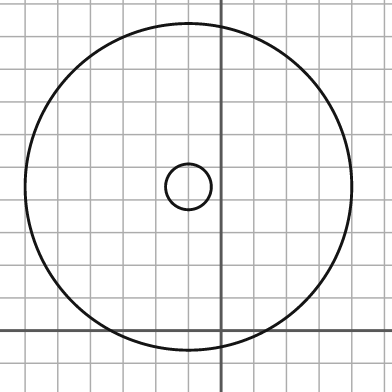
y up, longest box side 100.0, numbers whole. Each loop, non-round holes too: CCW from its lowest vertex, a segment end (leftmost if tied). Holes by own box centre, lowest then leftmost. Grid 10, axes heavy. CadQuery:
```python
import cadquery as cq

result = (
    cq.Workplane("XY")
    .moveTo(-10.0, 44.0)
    .circle(50.0)
    .moveTo(-10.0, 44.0)
    .circle(7.0)
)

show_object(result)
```